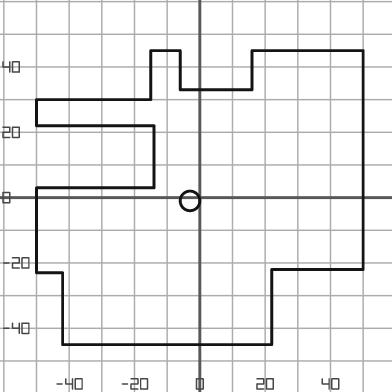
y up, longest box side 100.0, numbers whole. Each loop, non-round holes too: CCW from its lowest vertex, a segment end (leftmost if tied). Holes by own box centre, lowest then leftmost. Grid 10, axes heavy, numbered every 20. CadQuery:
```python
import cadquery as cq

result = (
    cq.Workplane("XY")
    .moveTo(-42.0, -45.0)
    .lineTo(22.0, -45.0)
    .lineTo(22.0, -22.0)
    .lineTo(50.0, -22.0)
    .lineTo(50.0, 45.0)
    .lineTo(16.0, 45.0)
    .lineTo(16.0, 33.0)
    .lineTo(-6.0, 33.0)
    .lineTo(-6.0, 45.0)
    .lineTo(-15.0, 45.0)
    .lineTo(-15.0, 30.0)
    .lineTo(-50.0, 30.0)
    .lineTo(-50.0, 22.0)
    .lineTo(-14.0, 22.0)
    .lineTo(-14.0, 3.0)
    .lineTo(-50.0, 3.0)
    .lineTo(-50.0, -23.0)
    .lineTo(-42.0, -23.0)
    .close()
    .moveTo(-3.0, -1.0)
    .circle(3.0)
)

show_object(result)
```